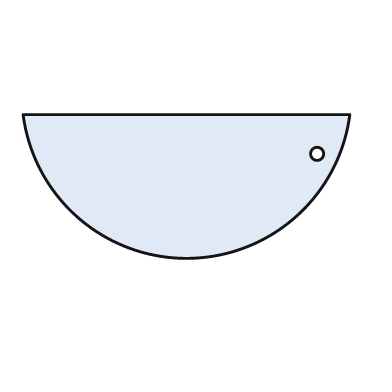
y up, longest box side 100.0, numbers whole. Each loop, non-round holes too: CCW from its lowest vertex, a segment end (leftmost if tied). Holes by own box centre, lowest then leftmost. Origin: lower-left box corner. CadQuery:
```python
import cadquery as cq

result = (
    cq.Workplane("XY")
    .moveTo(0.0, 44.0)
    .threePointArc((50.0, 0.0), (100.0, 44.0))
    .close()
    .moveTo(90.0, 32.0)
    .circle(2.0)
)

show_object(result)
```